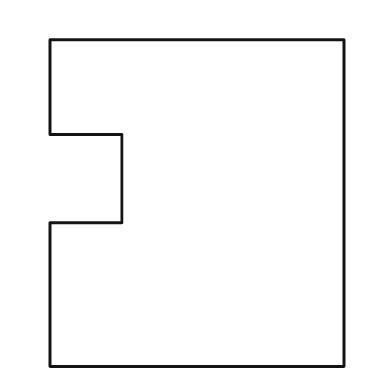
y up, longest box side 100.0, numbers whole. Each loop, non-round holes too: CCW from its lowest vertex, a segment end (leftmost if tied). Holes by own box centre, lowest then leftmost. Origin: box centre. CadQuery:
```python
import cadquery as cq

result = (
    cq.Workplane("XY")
    .moveTo(-45.0, -50.0)
    .lineTo(45.0, -50.0)
    .lineTo(45.0, 50.0)
    .lineTo(-45.0, 50.0)
    .lineTo(-45.0, 21.0)
    .lineTo(-23.0, 21.0)
    .lineTo(-23.0, -6.0)
    .lineTo(-45.0, -6.0)
    .close()
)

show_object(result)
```